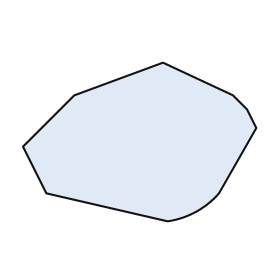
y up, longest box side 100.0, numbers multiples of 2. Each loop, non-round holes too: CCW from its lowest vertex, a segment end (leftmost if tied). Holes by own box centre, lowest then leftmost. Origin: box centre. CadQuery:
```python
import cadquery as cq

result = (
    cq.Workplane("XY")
    .moveTo(12.0, -34.0)
    .threePointArc((24.0, -30.0), (34.0, -22.0))
    .lineTo(50.0, 6.0)
    .lineTo(46.0, 14.0)
    .lineTo(40.0, 20.0)
    .lineTo(10.0, 34.0)
    .lineTo(-28.0, 20.0)
    .lineTo(-50.0, -2.0)
    .lineTo(-40.0, -22.0)
    .close()
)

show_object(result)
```